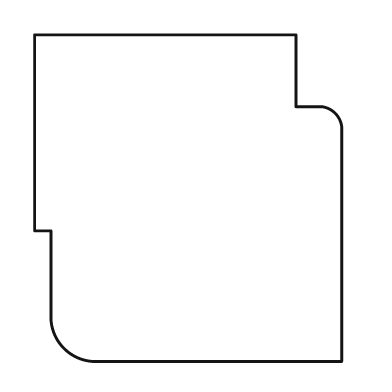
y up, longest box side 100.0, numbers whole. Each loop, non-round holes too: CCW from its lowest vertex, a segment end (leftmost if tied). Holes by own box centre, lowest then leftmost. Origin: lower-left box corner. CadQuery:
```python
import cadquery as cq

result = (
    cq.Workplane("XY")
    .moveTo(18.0, 0.0)
    .lineTo(94.0, 0.0)
    .lineTo(94.0, 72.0)
    .threePointArc((92.0, 76.0), (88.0, 78.0))
    .lineTo(80.0, 78.0)
    .lineTo(80.0, 100.0)
    .lineTo(0.0, 100.0)
    .lineTo(0.0, 40.0)
    .lineTo(5.0, 40.0)
    .lineTo(5.0, 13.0)
    .threePointArc((9.0, 4.0), (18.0, 0.0))
    .close()
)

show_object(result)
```